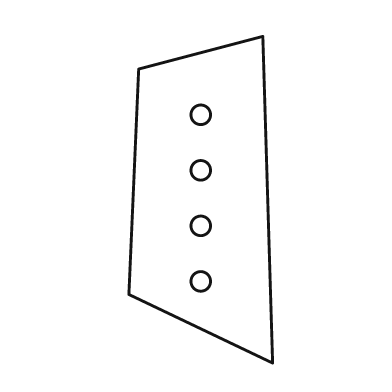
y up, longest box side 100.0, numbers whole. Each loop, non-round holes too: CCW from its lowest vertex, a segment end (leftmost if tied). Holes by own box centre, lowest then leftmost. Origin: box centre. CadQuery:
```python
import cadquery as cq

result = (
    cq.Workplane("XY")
    .moveTo(22.0, -50.0)
    .lineTo(19.0, 50.0)
    .lineTo(-19.0, 40.0)
    .lineTo(-22.0, -29.0)
    .close()
    .moveTo(0.0, -25.0)
    .circle(3.0)
    .moveTo(0.0, -8.0)
    .circle(3.0)
    .moveTo(0.0, 9.0)
    .circle(3.0)
    .moveTo(0.0, 26.0)
    .circle(3.0)
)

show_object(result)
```